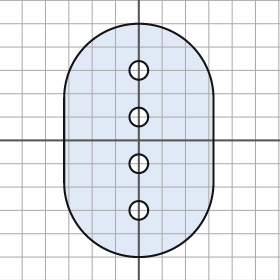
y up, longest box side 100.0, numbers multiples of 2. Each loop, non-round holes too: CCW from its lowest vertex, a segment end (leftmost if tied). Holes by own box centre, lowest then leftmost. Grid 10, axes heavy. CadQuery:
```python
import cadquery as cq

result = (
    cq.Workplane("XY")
    .moveTo(-32.0, -18.0)
    .threePointArc((0.0, -50.0), (32.0, -18.0))
    .lineTo(32.0, 18.0)
    .threePointArc((0.0, 50.0), (-32.0, 18.0))
    .close()
    .moveTo(0.0, -30.0)
    .circle(4.0)
    .moveTo(0.0, -10.0)
    .circle(4.0)
    .moveTo(0.0, 10.0)
    .circle(4.0)
    .moveTo(0.0, 30.0)
    .circle(4.0)
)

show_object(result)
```